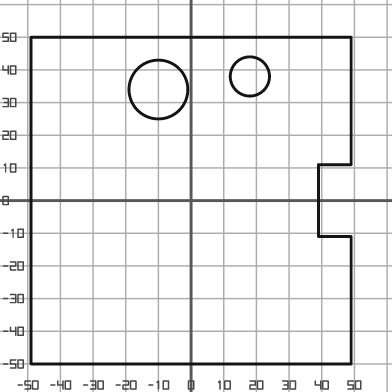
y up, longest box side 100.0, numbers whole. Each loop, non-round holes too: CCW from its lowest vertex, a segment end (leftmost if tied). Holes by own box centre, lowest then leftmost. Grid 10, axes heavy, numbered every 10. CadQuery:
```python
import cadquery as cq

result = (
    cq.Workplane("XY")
    .moveTo(-49.0, -50.0)
    .lineTo(49.0, -50.0)
    .lineTo(49.0, -11.0)
    .lineTo(39.0, -11.0)
    .lineTo(39.0, 11.0)
    .lineTo(49.0, 11.0)
    .lineTo(49.0, 50.0)
    .lineTo(-49.0, 50.0)
    .close()
    .moveTo(-10.0, 34.0)
    .circle(9.0)
    .moveTo(18.0, 38.0)
    .circle(6.0)
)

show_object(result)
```